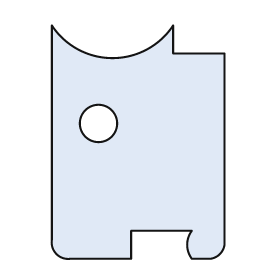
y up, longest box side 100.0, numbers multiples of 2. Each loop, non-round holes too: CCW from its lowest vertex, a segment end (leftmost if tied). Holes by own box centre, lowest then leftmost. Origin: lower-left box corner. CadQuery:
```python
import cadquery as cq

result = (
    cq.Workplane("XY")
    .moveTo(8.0, 0.0)
    .lineTo(34.0, 0.0)
    .lineTo(34.0, 12.0)
    .lineTo(60.0, 12.0)
    .threePointArc((58.0, 6.0), (60.0, 0.0))
    .lineTo(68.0, 0.0)
    .threePointArc((72.0, 2.0), (74.0, 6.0))
    .lineTo(74.0, 88.0)
    .lineTo(52.0, 88.0)
    .lineTo(52.0, 100.0)
    .threePointArc((26.0, 86.0), (0.0, 100.0))
    .lineTo(0.0, 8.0)
    .threePointArc((2.0, 2.0), (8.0, 0.0))
    .close()
    .moveTo(20.0, 58.0)
    .circle(8.0)
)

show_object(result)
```